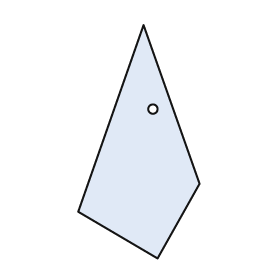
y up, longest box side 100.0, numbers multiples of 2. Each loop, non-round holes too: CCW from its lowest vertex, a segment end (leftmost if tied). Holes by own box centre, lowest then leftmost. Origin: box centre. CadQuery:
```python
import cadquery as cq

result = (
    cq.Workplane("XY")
    .moveTo(8.0, -50.0)
    .lineTo(26.0, -18.0)
    .lineTo(2.0, 50.0)
    .lineTo(-26.0, -30.0)
    .close()
    .moveTo(6.0, 14.0)
    .circle(2.0)
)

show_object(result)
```